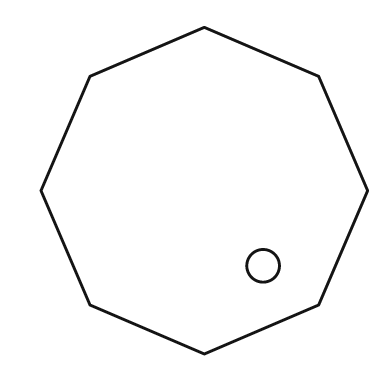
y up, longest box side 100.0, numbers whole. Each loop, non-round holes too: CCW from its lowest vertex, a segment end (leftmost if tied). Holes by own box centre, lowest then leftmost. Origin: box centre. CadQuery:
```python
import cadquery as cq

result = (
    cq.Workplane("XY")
    .moveTo(0.0, -50.0)
    .lineTo(35.0, -35.0)
    .lineTo(50.0, 0.0)
    .lineTo(35.0, 35.0)
    .lineTo(0.0, 50.0)
    .lineTo(-35.0, 35.0)
    .lineTo(-50.0, 0.0)
    .lineTo(-35.0, -35.0)
    .close()
    .moveTo(18.0, -23.0)
    .circle(5.0)
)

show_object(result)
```